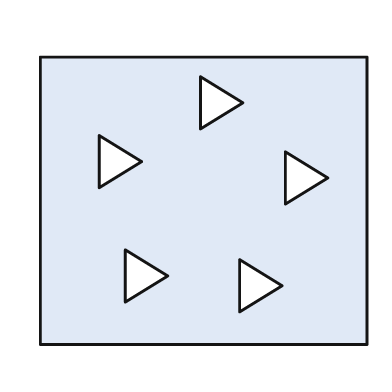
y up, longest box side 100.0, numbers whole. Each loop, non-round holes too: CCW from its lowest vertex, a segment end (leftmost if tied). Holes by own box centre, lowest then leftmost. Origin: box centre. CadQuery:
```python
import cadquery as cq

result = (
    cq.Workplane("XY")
    .moveTo(-50.0, -44.0)
    .lineTo(50.0, -44.0)
    .lineTo(50.0, 44.0)
    .lineTo(-50.0, 44.0)
    .close()
    .moveTo(11.0, -34.0)
    .lineTo(24.0, -26.0)
    .lineTo(11.0, -18.0)
    .close()
    .moveTo(-24.0, -31.0)
    .lineTo(-11.0, -23.0)
    .lineTo(-24.0, -15.0)
    .close()
    .moveTo(25.0, -1.0)
    .lineTo(38.0, 7.0)
    .lineTo(25.0, 15.0)
    .close()
    .moveTo(-32.0, 4.0)
    .lineTo(-19.0, 12.0)
    .lineTo(-32.0, 20.0)
    .close()
    .moveTo(-1.0, 22.0)
    .lineTo(12.0, 30.0)
    .lineTo(-1.0, 38.0)
    .close()
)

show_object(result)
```